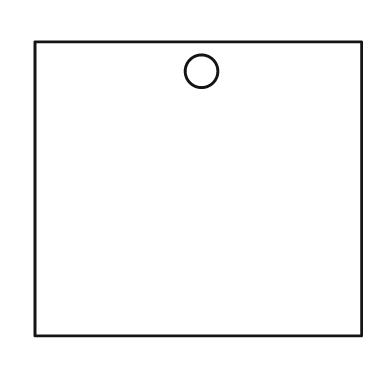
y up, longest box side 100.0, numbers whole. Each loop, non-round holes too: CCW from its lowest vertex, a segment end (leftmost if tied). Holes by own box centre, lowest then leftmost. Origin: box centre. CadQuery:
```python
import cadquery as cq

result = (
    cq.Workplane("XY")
    .moveTo(-50.0, -45.0)
    .lineTo(50.0, -45.0)
    .lineTo(50.0, 45.0)
    .lineTo(-50.0, 45.0)
    .close()
    .moveTo(1.0, 36.0)
    .circle(5.0)
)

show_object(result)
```